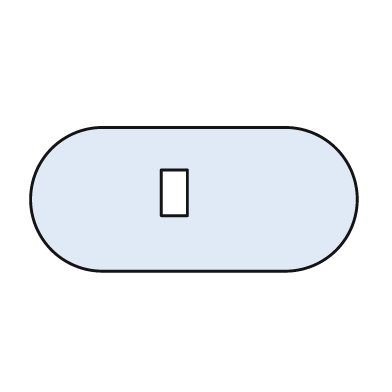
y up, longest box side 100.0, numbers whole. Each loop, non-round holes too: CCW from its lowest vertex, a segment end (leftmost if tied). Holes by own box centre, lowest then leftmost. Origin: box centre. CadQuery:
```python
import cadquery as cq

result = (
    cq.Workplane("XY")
    .moveTo(-28.0, -22.0)
    .lineTo(28.0, -22.0)
    .threePointArc((50.0, 0.0), (28.0, 22.0))
    .lineTo(-28.0, 22.0)
    .threePointArc((-50.0, 0.0), (-28.0, -22.0))
    .close()
    .moveTo(-10.0, -5.0)
    .lineTo(-2.0, -5.0)
    .lineTo(-2.0, 9.0)
    .lineTo(-10.0, 9.0)
    .close()
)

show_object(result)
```